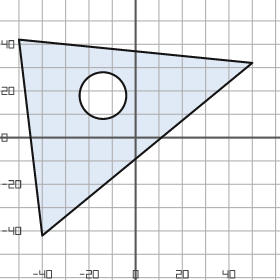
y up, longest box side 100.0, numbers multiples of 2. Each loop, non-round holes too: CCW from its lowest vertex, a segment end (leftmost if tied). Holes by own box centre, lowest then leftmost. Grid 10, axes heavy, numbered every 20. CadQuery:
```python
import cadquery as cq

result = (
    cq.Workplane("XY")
    .moveTo(-40.0, -42.0)
    .lineTo(50.0, 32.0)
    .lineTo(-50.0, 42.0)
    .close()
    .moveTo(-14.0, 18.0)
    .circle(10.0)
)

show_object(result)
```